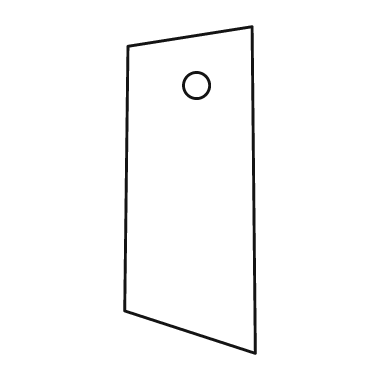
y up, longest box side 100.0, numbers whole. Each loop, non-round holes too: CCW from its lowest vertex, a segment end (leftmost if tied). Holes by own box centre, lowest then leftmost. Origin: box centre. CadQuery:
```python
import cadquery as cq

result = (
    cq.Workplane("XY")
    .moveTo(20.0, -50.0)
    .lineTo(19.0, 50.0)
    .lineTo(-19.0, 44.0)
    .lineTo(-20.0, -37.0)
    .close()
    .moveTo(2.0, 32.0)
    .circle(4.0)
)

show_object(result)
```